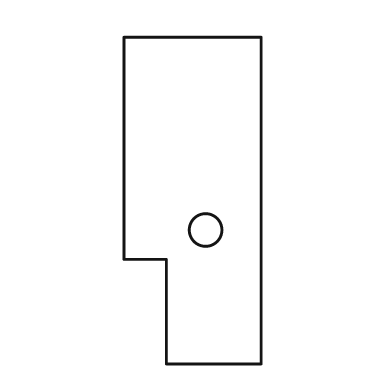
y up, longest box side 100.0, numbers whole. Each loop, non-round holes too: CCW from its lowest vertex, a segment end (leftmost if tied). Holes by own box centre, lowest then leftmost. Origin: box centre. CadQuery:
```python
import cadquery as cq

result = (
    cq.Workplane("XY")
    .moveTo(-8.0, -50.0)
    .lineTo(21.0, -50.0)
    .lineTo(21.0, 50.0)
    .lineTo(-21.0, 50.0)
    .lineTo(-21.0, -18.0)
    .lineTo(-8.0, -18.0)
    .close()
    .moveTo(4.0, -9.0)
    .circle(5.0)
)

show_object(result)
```